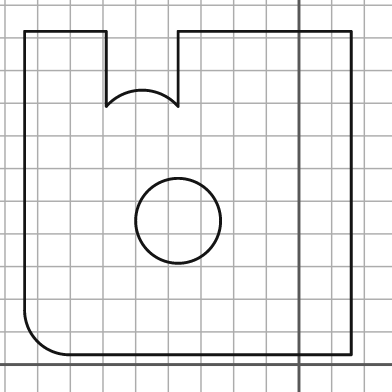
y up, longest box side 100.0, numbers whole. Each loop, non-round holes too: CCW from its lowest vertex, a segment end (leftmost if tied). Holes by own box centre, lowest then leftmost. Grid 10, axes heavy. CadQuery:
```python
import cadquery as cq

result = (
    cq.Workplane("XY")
    .moveTo(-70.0, 3.0)
    .lineTo(16.0, 3.0)
    .lineTo(16.0, 102.0)
    .lineTo(-37.0, 102.0)
    .lineTo(-37.0, 79.0)
    .threePointArc((-48.0, 84.0), (-59.0, 79.0))
    .lineTo(-59.0, 102.0)
    .lineTo(-84.0, 102.0)
    .lineTo(-84.0, 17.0)
    .threePointArc((-80.0, 7.0), (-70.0, 3.0))
    .close()
    .moveTo(-37.0, 44.0)
    .circle(13.0)
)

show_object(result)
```